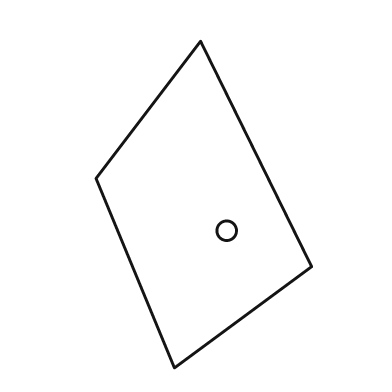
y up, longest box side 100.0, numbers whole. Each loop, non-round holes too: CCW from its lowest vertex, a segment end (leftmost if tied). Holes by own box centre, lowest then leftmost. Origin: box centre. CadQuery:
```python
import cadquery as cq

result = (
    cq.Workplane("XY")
    .moveTo(-9.0, -50.0)
    .lineTo(33.0, -19.0)
    .lineTo(-1.0, 50.0)
    .lineTo(-33.0, 8.0)
    .close()
    .moveTo(7.0, -8.0)
    .circle(3.0)
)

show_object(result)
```